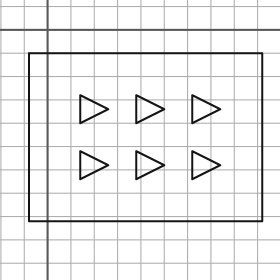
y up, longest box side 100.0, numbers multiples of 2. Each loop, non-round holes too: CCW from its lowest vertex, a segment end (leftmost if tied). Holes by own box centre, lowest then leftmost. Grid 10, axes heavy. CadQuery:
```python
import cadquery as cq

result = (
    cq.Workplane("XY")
    .moveTo(-8.0, -82.0)
    .lineTo(92.0, -82.0)
    .lineTo(92.0, -10.0)
    .lineTo(-8.0, -10.0)
    .close()
    .moveTo(14.0, -64.0)
    .lineTo(26.0, -58.0)
    .lineTo(14.0, -52.0)
    .close()
    .moveTo(38.0, -64.0)
    .lineTo(50.0, -58.0)
    .lineTo(38.0, -52.0)
    .close()
    .moveTo(62.0, -64.0)
    .lineTo(74.0, -58.0)
    .lineTo(62.0, -52.0)
    .close()
    .moveTo(14.0, -40.0)
    .lineTo(26.0, -34.0)
    .lineTo(14.0, -28.0)
    .close()
    .moveTo(38.0, -40.0)
    .lineTo(50.0, -34.0)
    .lineTo(38.0, -28.0)
    .close()
    .moveTo(62.0, -40.0)
    .lineTo(74.0, -34.0)
    .lineTo(62.0, -28.0)
    .close()
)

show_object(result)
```